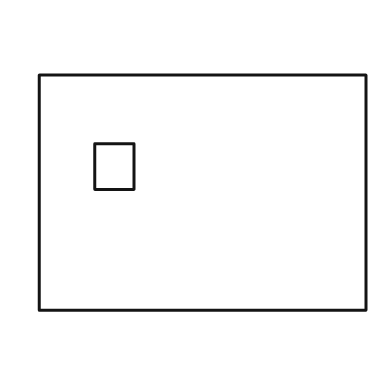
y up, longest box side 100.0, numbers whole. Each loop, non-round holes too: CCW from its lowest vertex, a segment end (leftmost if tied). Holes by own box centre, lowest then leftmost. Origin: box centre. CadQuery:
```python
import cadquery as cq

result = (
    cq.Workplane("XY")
    .moveTo(-50.0, -36.0)
    .lineTo(50.0, -36.0)
    .lineTo(50.0, 36.0)
    .lineTo(-50.0, 36.0)
    .close()
    .moveTo(-33.0, 1.0)
    .lineTo(-21.0, 1.0)
    .lineTo(-21.0, 15.0)
    .lineTo(-33.0, 15.0)
    .close()
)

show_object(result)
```